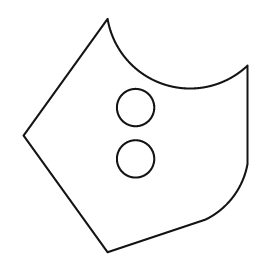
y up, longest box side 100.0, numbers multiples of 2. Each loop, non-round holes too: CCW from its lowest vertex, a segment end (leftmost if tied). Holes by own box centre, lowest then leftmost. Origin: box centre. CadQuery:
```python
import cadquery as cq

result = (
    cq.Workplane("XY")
    .moveTo(-12.0, -50.0)
    .lineTo(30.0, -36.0)
    .threePointArc((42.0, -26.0), (48.0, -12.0))
    .lineTo(48.0, 30.0)
    .threePointArc((12.0, 22.0), (-12.0, 50.0))
    .lineTo(-48.0, 0.0)
    .close()
    .moveTo(0.0, -10.0)
    .circle(8.0)
    .moveTo(0.0, 12.0)
    .circle(8.0)
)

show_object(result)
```